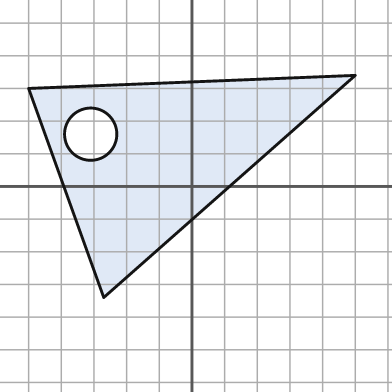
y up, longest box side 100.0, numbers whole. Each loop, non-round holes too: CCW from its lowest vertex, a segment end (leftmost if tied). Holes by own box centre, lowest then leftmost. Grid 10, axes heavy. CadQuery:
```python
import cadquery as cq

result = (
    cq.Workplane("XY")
    .moveTo(-27.0, -34.0)
    .lineTo(50.0, 34.0)
    .lineTo(-50.0, 30.0)
    .close()
    .moveTo(-31.0, 16.0)
    .circle(8.0)
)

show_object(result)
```